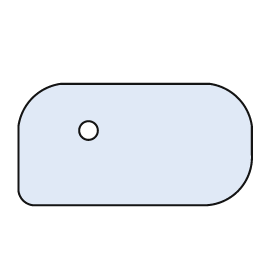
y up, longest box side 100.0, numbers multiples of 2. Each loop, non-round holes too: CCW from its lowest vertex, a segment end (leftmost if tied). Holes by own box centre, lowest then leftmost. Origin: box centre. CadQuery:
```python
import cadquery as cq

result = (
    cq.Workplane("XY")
    .moveTo(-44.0, -26.0)
    .lineTo(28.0, -26.0)
    .threePointArc((44.0, -20.0), (50.0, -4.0))
    .lineTo(50.0, 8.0)
    .threePointArc((44.0, 20.0), (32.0, 26.0))
    .lineTo(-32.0, 26.0)
    .threePointArc((-44.0, 20.0), (-50.0, 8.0))
    .lineTo(-50.0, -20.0)
    .threePointArc((-48.0, -24.0), (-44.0, -26.0))
    .close()
    .moveTo(-20.0, 6.0)
    .circle(4.0)
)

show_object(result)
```